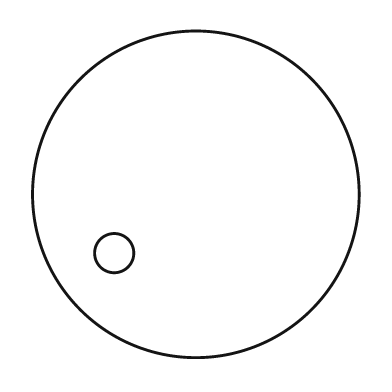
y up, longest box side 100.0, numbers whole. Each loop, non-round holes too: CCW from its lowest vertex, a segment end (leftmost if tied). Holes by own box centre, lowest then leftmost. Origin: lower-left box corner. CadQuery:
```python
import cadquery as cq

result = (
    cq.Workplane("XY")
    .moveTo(50.0, 50.0)
    .circle(50.0)
    .moveTo(25.0, 32.0)
    .circle(6.0)
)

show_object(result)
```